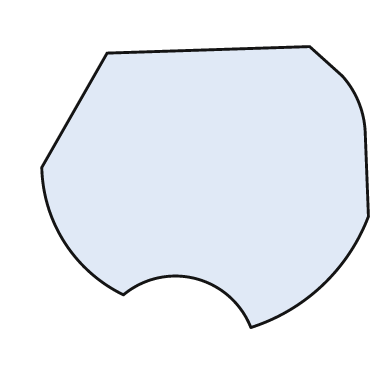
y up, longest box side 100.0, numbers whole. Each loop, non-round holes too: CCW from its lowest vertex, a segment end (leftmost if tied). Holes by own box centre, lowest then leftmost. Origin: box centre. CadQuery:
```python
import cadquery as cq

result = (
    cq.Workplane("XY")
    .moveTo(14.0, -43.0)
    .threePointArc((36.0, -30.0), (50.0, -9.0))
    .lineTo(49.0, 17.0)
    .threePointArc((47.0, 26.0), (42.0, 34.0))
    .lineTo(32.0, 43.0)
    .lineTo(-30.0, 41.0)
    .lineTo(-50.0, 6.0)
    .threePointArc((-43.0, -17.0), (-25.0, -33.0))
    .threePointArc((-3.0, -28.0), (14.0, -43.0))
    .close()
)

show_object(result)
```